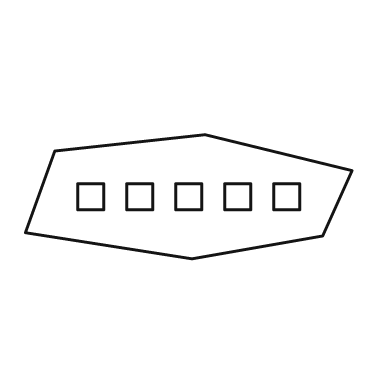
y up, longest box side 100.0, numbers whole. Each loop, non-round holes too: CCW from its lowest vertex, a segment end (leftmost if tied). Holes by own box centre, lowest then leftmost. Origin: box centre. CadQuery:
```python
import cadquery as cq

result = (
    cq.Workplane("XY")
    .moveTo(1.0, -19.0)
    .lineTo(41.0, -12.0)
    .lineTo(50.0, 8.0)
    .lineTo(5.0, 19.0)
    .lineTo(-41.0, 14.0)
    .lineTo(-50.0, -11.0)
    .close()
    .moveTo(-34.0, -4.0)
    .lineTo(-26.0, -4.0)
    .lineTo(-26.0, 4.0)
    .lineTo(-34.0, 4.0)
    .close()
    .moveTo(-19.0, -4.0)
    .lineTo(-11.0, -4.0)
    .lineTo(-11.0, 4.0)
    .lineTo(-19.0, 4.0)
    .close()
    .moveTo(-4.0, -4.0)
    .lineTo(4.0, -4.0)
    .lineTo(4.0, 4.0)
    .lineTo(-4.0, 4.0)
    .close()
    .moveTo(11.0, -4.0)
    .lineTo(19.0, -4.0)
    .lineTo(19.0, 4.0)
    .lineTo(11.0, 4.0)
    .close()
    .moveTo(26.0, -4.0)
    .lineTo(34.0, -4.0)
    .lineTo(34.0, 4.0)
    .lineTo(26.0, 4.0)
    .close()
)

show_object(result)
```